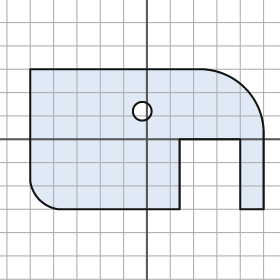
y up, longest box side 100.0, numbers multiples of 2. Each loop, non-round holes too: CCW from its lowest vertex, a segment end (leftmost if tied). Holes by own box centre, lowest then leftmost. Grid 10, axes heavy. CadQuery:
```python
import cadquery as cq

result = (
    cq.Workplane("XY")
    .moveTo(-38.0, -30.0)
    .lineTo(14.0, -30.0)
    .lineTo(14.0, 0.0)
    .lineTo(40.0, 0.0)
    .lineTo(40.0, -30.0)
    .lineTo(50.0, -30.0)
    .lineTo(50.0, 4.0)
    .threePointArc((42.0, 22.0), (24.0, 30.0))
    .lineTo(-50.0, 30.0)
    .lineTo(-50.0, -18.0)
    .threePointArc((-46.0, -26.0), (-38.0, -30.0))
    .close()
    .moveTo(-2.0, 12.0)
    .circle(4.0)
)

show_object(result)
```